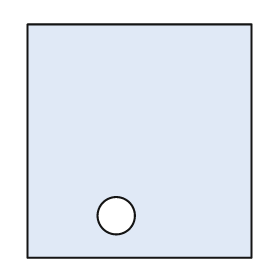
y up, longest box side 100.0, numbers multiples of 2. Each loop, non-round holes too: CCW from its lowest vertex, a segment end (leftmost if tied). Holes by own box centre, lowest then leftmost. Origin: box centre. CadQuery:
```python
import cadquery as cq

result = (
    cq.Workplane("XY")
    .moveTo(-48.0, -50.0)
    .lineTo(48.0, -50.0)
    .lineTo(48.0, 50.0)
    .lineTo(-48.0, 50.0)
    .close()
    .moveTo(-10.0, -32.0)
    .circle(8.0)
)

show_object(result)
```